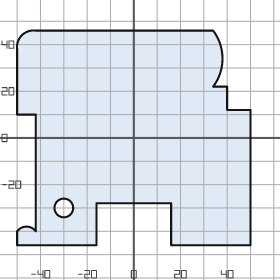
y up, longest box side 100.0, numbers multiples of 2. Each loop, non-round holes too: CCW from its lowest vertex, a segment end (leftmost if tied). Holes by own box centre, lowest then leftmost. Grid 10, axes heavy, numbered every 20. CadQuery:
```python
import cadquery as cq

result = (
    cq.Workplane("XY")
    .moveTo(-50.0, -46.0)
    .lineTo(-16.0, -46.0)
    .lineTo(-16.0, -28.0)
    .lineTo(16.0, -28.0)
    .lineTo(16.0, -46.0)
    .lineTo(50.0, -46.0)
    .lineTo(50.0, 12.0)
    .lineTo(40.0, 12.0)
    .lineTo(40.0, 22.0)
    .lineTo(34.0, 22.0)
    .threePointArc((38.0, 34.0), (34.0, 46.0))
    .lineTo(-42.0, 46.0)
    .threePointArc((-48.0, 44.0), (-50.0, 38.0))
    .lineTo(-50.0, 10.0)
    .lineTo(-42.0, 10.0)
    .lineTo(-42.0, -40.0)
    .threePointArc((-46.0, -38.0), (-50.0, -40.0))
    .close()
    .moveTo(-30.0, -30.0)
    .circle(4.0)
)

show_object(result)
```